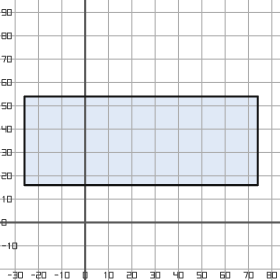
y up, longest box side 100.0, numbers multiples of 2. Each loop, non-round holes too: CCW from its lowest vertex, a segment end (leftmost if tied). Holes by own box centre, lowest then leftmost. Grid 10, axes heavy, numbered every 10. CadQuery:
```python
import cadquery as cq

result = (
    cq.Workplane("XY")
    .moveTo(-26.0, 16.0)
    .lineTo(74.0, 16.0)
    .lineTo(74.0, 54.0)
    .lineTo(-26.0, 54.0)
    .close()
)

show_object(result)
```